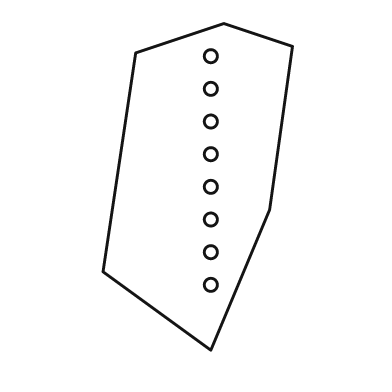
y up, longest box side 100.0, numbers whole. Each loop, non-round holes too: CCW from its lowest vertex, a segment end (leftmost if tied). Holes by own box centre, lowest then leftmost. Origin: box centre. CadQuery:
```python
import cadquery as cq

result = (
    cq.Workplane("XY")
    .moveTo(4.0, -50.0)
    .lineTo(22.0, -7.0)
    .lineTo(29.0, 43.0)
    .lineTo(8.0, 50.0)
    .lineTo(-19.0, 41.0)
    .lineTo(-29.0, -26.0)
    .close()
    .moveTo(4.0, -30.0)
    .circle(2.0)
    .moveTo(4.0, -20.0)
    .circle(2.0)
    .moveTo(4.0, -10.0)
    .circle(2.0)
    .moveTo(4.0, 0.0)
    .circle(2.0)
    .moveTo(4.0, 10.0)
    .circle(2.0)
    .moveTo(4.0, 20.0)
    .circle(2.0)
    .moveTo(4.0, 30.0)
    .circle(2.0)
    .moveTo(4.0, 40.0)
    .circle(2.0)
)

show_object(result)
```